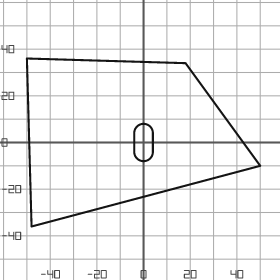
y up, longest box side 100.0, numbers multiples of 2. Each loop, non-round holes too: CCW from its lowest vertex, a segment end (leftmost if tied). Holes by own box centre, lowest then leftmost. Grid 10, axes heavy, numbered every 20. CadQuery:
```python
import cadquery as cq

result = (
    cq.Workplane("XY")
    .moveTo(-48.0, -36.0)
    .lineTo(50.0, -10.0)
    .lineTo(18.0, 34.0)
    .lineTo(-50.0, 36.0)
    .close()
    .moveTo(-4.0, -4.0)
    .threePointArc((0.0, -8.0), (4.0, -4.0))
    .lineTo(4.0, 4.0)
    .threePointArc((0.0, 8.0), (-4.0, 4.0))
    .close()
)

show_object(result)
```